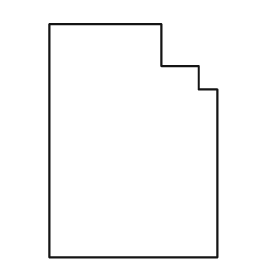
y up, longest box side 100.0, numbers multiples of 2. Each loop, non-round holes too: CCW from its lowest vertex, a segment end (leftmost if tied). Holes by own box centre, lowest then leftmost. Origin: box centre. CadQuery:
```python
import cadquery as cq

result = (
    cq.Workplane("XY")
    .moveTo(-36.0, -50.0)
    .lineTo(36.0, -50.0)
    .lineTo(36.0, 22.0)
    .lineTo(28.0, 22.0)
    .lineTo(28.0, 32.0)
    .lineTo(12.0, 32.0)
    .lineTo(12.0, 50.0)
    .lineTo(-36.0, 50.0)
    .close()
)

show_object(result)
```